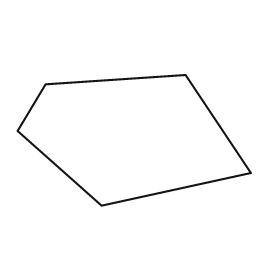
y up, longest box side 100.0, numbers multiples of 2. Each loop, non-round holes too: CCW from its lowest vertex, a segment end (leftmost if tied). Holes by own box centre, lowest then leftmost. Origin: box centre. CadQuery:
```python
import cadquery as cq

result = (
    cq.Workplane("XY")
    .moveTo(-14.0, -28.0)
    .lineTo(50.0, -14.0)
    .lineTo(22.0, 28.0)
    .lineTo(-38.0, 24.0)
    .lineTo(-50.0, 4.0)
    .close()
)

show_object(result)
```